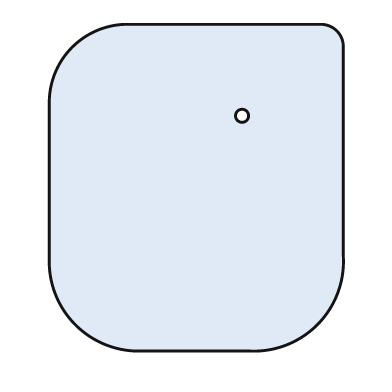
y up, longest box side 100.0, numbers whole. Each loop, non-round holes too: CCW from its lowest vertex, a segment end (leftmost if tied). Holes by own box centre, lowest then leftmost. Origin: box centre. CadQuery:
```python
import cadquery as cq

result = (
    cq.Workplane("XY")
    .moveTo(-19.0, -50.0)
    .lineTo(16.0, -50.0)
    .threePointArc((37.0, -42.0), (45.0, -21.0))
    .lineTo(45.0, 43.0)
    .threePointArc((43.0, 48.0), (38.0, 50.0))
    .lineTo(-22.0, 50.0)
    .threePointArc((-38.0, 43.0), (-45.0, 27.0))
    .lineTo(-45.0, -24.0)
    .threePointArc((-37.0, -42.0), (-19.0, -50.0))
    .close()
    .moveTo(14.0, 22.0)
    .circle(2.0)
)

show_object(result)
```